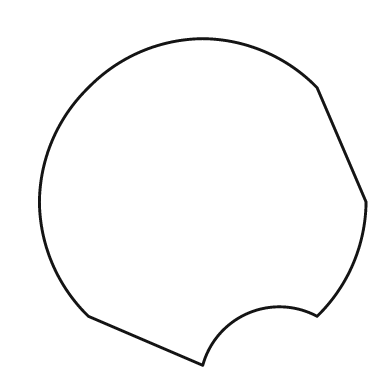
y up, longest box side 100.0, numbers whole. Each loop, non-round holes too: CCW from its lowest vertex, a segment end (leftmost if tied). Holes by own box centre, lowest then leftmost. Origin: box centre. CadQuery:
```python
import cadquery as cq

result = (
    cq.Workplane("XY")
    .moveTo(0.0, -50.0)
    .threePointArc((14.0, -34.0), (35.0, -35.0))
    .threePointArc((46.0, -19.0), (50.0, 0.0))
    .lineTo(35.0, 35.0)
    .threePointArc((19.0, 46.0), (0.0, 50.0))
    .threePointArc((-19.0, 46.0), (-35.0, 35.0))
    .threePointArc((-46.0, 19.0), (-50.0, 0.0))
    .threePointArc((-46.0, -19.0), (-35.0, -35.0))
    .close()
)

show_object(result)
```